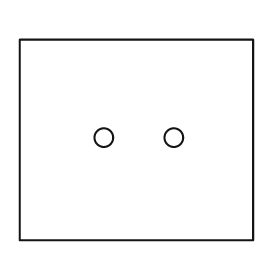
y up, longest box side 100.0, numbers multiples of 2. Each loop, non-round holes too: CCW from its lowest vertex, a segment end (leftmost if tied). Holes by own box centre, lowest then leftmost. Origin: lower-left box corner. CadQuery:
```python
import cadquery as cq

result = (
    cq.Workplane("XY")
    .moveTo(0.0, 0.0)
    .lineTo(100.0, 0.0)
    .lineTo(100.0, 86.0)
    .lineTo(0.0, 86.0)
    .close()
    .moveTo(36.0, 44.0)
    .circle(4.0)
    .moveTo(66.0, 44.0)
    .circle(4.0)
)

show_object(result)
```